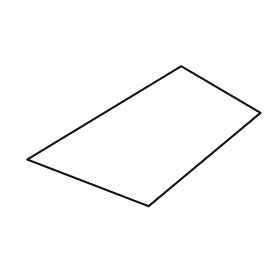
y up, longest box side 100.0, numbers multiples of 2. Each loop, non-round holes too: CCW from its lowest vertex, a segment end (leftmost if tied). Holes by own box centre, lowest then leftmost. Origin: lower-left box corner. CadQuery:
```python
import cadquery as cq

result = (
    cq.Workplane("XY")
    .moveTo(52.0, 0.0)
    .lineTo(100.0, 40.0)
    .lineTo(66.0, 60.0)
    .lineTo(0.0, 20.0)
    .close()
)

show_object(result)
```